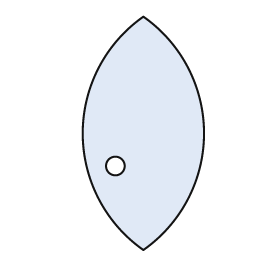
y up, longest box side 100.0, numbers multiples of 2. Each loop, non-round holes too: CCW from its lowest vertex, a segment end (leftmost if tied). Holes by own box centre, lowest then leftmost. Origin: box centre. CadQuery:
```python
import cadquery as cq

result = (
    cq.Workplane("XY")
    .moveTo(0.0, -50.0)
    .threePointArc((26.0, 0.0), (0.0, 50.0))
    .threePointArc((-26.0, 0.0), (0.0, -50.0))
    .close()
    .moveTo(-12.0, -14.0)
    .circle(4.0)
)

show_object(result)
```